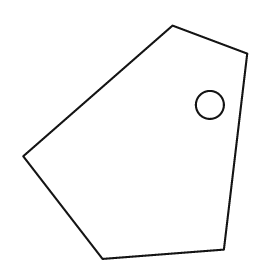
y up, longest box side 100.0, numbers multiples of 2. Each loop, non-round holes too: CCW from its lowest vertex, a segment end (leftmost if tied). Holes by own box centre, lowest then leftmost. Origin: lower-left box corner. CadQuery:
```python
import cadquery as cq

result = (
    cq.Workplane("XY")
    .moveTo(34.0, 0.0)
    .lineTo(86.0, 4.0)
    .lineTo(96.0, 88.0)
    .lineTo(64.0, 100.0)
    .lineTo(0.0, 44.0)
    .close()
    .moveTo(80.0, 66.0)
    .circle(6.0)
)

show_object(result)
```